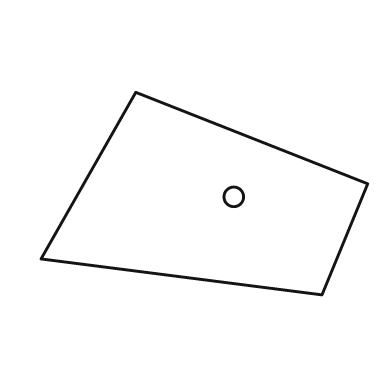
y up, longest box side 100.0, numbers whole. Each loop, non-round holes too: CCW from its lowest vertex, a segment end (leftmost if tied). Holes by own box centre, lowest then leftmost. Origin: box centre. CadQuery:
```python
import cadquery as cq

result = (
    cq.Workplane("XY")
    .moveTo(36.0, -31.0)
    .lineTo(50.0, 3.0)
    .lineTo(-21.0, 31.0)
    .lineTo(-50.0, -20.0)
    .close()
    .moveTo(9.0, -1.0)
    .circle(3.0)
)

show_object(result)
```